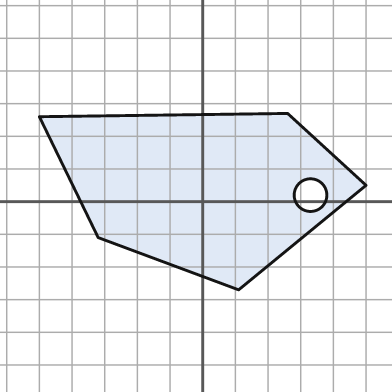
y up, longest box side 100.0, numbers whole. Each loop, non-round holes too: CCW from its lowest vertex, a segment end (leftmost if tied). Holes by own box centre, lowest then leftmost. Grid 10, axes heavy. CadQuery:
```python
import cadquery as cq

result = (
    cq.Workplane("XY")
    .moveTo(11.0, -27.0)
    .lineTo(50.0, 5.0)
    .lineTo(26.0, 27.0)
    .lineTo(-50.0, 26.0)
    .lineTo(-32.0, -11.0)
    .close()
    .moveTo(33.0, 2.0)
    .circle(5.0)
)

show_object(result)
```